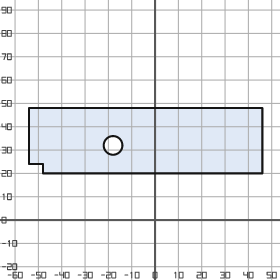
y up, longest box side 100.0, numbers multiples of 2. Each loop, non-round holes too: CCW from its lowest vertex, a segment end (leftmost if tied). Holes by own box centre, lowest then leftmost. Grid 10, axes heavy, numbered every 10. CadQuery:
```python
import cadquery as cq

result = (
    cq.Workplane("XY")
    .moveTo(-48.0, 20.0)
    .lineTo(46.0, 20.0)
    .lineTo(46.0, 48.0)
    .lineTo(-54.0, 48.0)
    .lineTo(-54.0, 24.0)
    .lineTo(-48.0, 24.0)
    .close()
    .moveTo(-18.0, 32.0)
    .circle(4.0)
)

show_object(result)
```